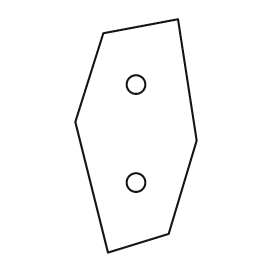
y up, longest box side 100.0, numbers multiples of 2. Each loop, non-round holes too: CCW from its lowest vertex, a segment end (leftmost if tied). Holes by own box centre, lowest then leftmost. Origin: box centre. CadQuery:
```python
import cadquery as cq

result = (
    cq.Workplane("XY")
    .moveTo(-12.0, -50.0)
    .lineTo(14.0, -42.0)
    .lineTo(26.0, -2.0)
    .lineTo(18.0, 50.0)
    .lineTo(-14.0, 44.0)
    .lineTo(-26.0, 6.0)
    .close()
    .moveTo(0.0, -20.0)
    .circle(4.0)
    .moveTo(0.0, 22.0)
    .circle(4.0)
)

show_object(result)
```